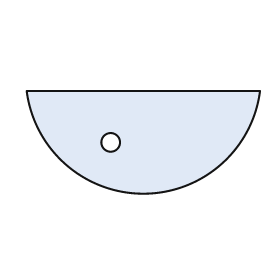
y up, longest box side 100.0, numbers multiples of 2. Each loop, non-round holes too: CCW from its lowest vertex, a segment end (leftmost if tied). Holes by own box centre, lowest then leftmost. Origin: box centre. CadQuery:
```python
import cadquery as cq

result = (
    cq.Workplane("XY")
    .moveTo(-50.0, 22.0)
    .threePointArc((0.0, -22.0), (50.0, 22.0))
    .close()
    .moveTo(-14.0, 0.0)
    .circle(4.0)
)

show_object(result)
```